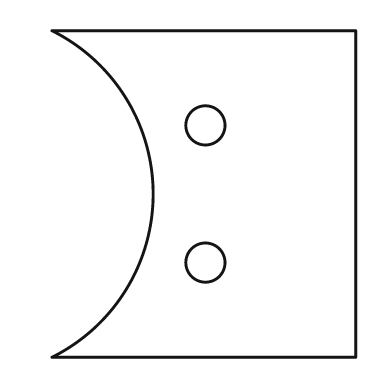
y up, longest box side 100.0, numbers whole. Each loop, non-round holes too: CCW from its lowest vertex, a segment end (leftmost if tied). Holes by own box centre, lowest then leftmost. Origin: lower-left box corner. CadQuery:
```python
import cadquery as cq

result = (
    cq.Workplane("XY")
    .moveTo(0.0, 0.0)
    .lineTo(93.0, 0.0)
    .lineTo(93.0, 100.0)
    .lineTo(0.0, 100.0)
    .threePointArc((31.0, 50.0), (0.0, 0.0))
    .close()
    .moveTo(47.0, 29.0)
    .circle(6.0)
    .moveTo(47.0, 71.0)
    .circle(6.0)
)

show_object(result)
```